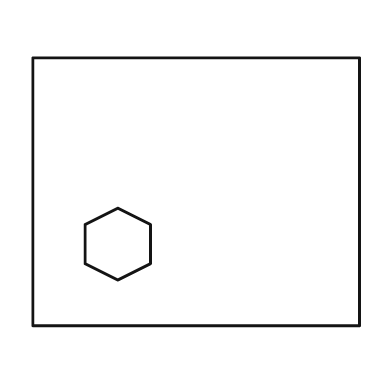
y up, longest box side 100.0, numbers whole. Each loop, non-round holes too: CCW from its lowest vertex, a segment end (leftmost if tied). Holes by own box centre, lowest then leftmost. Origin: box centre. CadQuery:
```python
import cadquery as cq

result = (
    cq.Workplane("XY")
    .moveTo(-50.0, -41.0)
    .lineTo(50.0, -41.0)
    .lineTo(50.0, 41.0)
    .lineTo(-50.0, 41.0)
    .close()
    .moveTo(-24.0, -27.0)
    .lineTo(-14.0, -22.0)
    .lineTo(-14.0, -10.0)
    .lineTo(-24.0, -5.0)
    .lineTo(-34.0, -10.0)
    .lineTo(-34.0, -22.0)
    .close()
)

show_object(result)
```